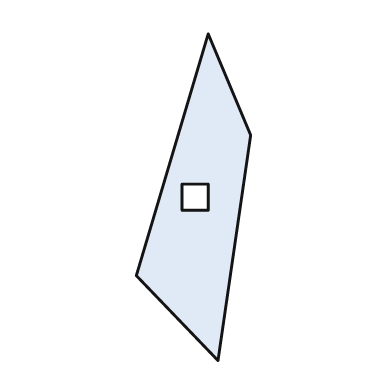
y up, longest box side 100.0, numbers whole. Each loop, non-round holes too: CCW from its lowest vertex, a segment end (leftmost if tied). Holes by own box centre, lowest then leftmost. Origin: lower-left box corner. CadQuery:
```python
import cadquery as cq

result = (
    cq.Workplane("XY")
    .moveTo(25.0, 0.0)
    .lineTo(35.0, 69.0)
    .lineTo(22.0, 100.0)
    .lineTo(0.0, 26.0)
    .close()
    .moveTo(14.0, 46.0)
    .lineTo(22.0, 46.0)
    .lineTo(22.0, 54.0)
    .lineTo(14.0, 54.0)
    .close()
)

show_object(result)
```